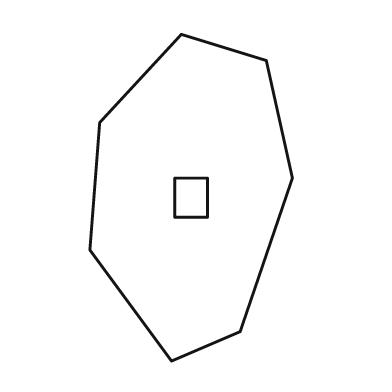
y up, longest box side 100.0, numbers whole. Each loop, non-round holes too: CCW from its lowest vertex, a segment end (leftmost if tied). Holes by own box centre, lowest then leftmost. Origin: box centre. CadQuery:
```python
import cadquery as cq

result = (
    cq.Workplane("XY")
    .moveTo(-6.0, -50.0)
    .lineTo(15.0, -41.0)
    .lineTo(31.0, 6.0)
    .lineTo(23.0, 42.0)
    .lineTo(-3.0, 50.0)
    .lineTo(-28.0, 23.0)
    .lineTo(-31.0, -16.0)
    .close()
    .moveTo(-5.0, -6.0)
    .lineTo(5.0, -6.0)
    .lineTo(5.0, 6.0)
    .lineTo(-5.0, 6.0)
    .close()
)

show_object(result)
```